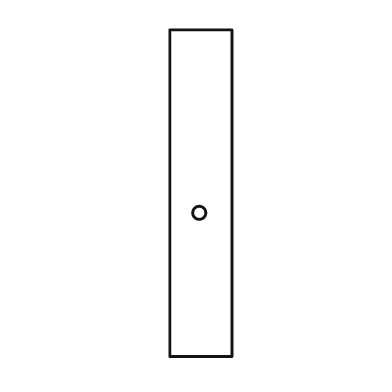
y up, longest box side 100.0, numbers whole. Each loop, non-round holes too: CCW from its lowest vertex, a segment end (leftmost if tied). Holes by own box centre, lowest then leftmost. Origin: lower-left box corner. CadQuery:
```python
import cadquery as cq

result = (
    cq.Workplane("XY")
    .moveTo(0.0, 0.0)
    .lineTo(19.0, 0.0)
    .lineTo(19.0, 100.0)
    .lineTo(0.0, 100.0)
    .close()
    .moveTo(9.0, 44.0)
    .circle(2.0)
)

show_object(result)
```